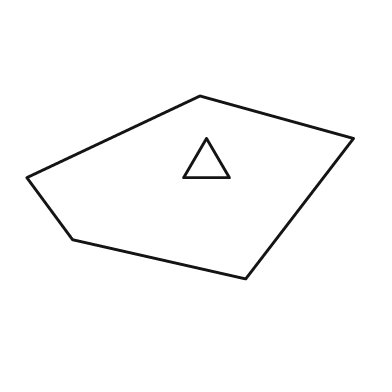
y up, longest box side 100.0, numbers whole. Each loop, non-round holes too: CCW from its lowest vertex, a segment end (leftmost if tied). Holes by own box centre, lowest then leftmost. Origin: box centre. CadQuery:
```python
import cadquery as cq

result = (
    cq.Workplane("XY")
    .moveTo(17.0, -28.0)
    .lineTo(50.0, 15.0)
    .lineTo(3.0, 28.0)
    .lineTo(-50.0, 3.0)
    .lineTo(-36.0, -16.0)
    .close()
    .moveTo(-2.0, 3.0)
    .lineTo(12.0, 3.0)
    .lineTo(5.0, 15.0)
    .close()
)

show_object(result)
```